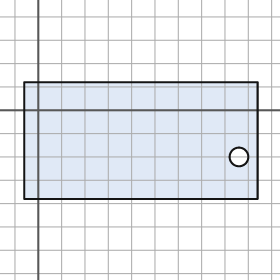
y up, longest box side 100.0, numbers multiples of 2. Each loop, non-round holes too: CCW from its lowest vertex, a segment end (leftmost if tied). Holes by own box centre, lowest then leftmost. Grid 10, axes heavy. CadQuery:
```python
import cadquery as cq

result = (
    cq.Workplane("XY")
    .moveTo(-6.0, -38.0)
    .lineTo(94.0, -38.0)
    .lineTo(94.0, 12.0)
    .lineTo(-6.0, 12.0)
    .close()
    .moveTo(86.0, -20.0)
    .circle(4.0)
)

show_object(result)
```